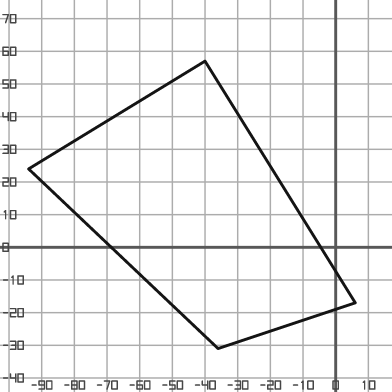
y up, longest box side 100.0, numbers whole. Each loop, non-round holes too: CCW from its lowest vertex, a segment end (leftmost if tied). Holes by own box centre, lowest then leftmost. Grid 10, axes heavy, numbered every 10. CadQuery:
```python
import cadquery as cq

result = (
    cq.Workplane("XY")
    .moveTo(-36.0, -31.0)
    .lineTo(6.0, -17.0)
    .lineTo(-40.0, 57.0)
    .lineTo(-94.0, 24.0)
    .close()
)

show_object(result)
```